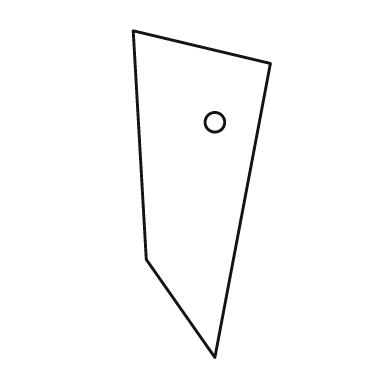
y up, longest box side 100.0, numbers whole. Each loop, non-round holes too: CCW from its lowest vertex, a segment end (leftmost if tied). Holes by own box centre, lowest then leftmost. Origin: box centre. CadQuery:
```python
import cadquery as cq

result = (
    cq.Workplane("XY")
    .moveTo(4.0, -50.0)
    .lineTo(21.0, 40.0)
    .lineTo(-21.0, 50.0)
    .lineTo(-17.0, -20.0)
    .close()
    .moveTo(4.0, 22.0)
    .circle(3.0)
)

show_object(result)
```